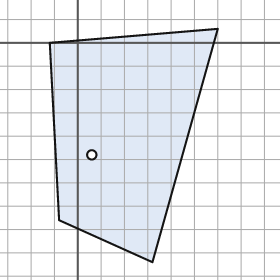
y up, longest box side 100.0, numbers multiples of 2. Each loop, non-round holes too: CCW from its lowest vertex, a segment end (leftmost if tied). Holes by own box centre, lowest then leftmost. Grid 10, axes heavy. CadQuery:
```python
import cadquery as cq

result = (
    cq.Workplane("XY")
    .moveTo(32.0, -94.0)
    .lineTo(60.0, 6.0)
    .lineTo(-12.0, 0.0)
    .lineTo(-8.0, -76.0)
    .close()
    .moveTo(6.0, -48.0)
    .circle(2.0)
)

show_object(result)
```